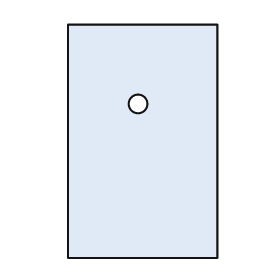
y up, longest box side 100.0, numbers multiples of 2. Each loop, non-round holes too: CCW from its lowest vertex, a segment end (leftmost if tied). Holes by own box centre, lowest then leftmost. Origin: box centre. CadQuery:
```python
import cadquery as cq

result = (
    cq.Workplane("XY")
    .moveTo(-32.0, -50.0)
    .lineTo(32.0, -50.0)
    .lineTo(32.0, 50.0)
    .lineTo(-32.0, 50.0)
    .close()
    .moveTo(-2.0, 16.0)
    .circle(4.0)
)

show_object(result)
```